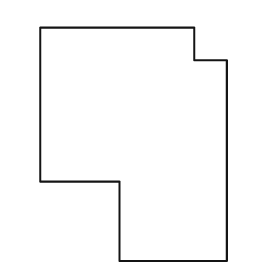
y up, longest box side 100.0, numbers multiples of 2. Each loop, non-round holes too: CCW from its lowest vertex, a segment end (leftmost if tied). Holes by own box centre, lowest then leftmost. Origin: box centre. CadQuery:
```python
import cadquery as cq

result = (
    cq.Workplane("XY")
    .moveTo(-6.0, -50.0)
    .lineTo(40.0, -50.0)
    .lineTo(40.0, 36.0)
    .lineTo(26.0, 36.0)
    .lineTo(26.0, 50.0)
    .lineTo(-40.0, 50.0)
    .lineTo(-40.0, -16.0)
    .lineTo(-6.0, -16.0)
    .close()
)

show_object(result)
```